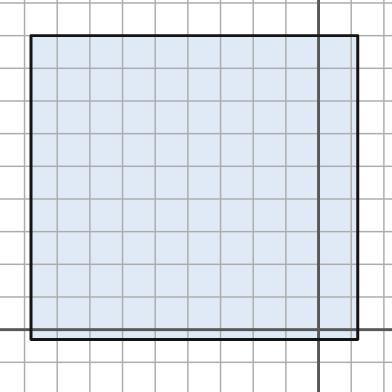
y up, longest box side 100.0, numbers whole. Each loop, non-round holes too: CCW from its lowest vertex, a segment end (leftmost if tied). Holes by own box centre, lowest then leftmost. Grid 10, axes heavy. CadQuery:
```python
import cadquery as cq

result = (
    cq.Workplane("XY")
    .moveTo(-88.0, -3.0)
    .lineTo(12.0, -3.0)
    .lineTo(12.0, 90.0)
    .lineTo(-88.0, 90.0)
    .close()
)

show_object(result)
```